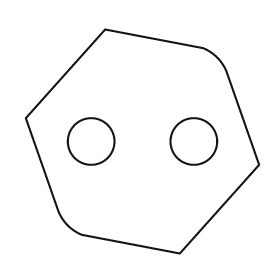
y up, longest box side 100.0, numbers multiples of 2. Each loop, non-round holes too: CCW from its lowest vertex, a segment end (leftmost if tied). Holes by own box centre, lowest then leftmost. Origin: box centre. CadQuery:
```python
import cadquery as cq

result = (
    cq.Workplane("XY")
    .moveTo(16.0, -48.0)
    .lineTo(50.0, -10.0)
    .lineTo(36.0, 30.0)
    .threePointArc((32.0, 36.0), (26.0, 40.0))
    .lineTo(-16.0, 48.0)
    .lineTo(-50.0, 10.0)
    .lineTo(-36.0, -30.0)
    .threePointArc((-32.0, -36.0), (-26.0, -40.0))
    .close()
    .moveTo(-22.0, 0.0)
    .circle(10.0)
    .moveTo(22.0, 0.0)
    .circle(10.0)
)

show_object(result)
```